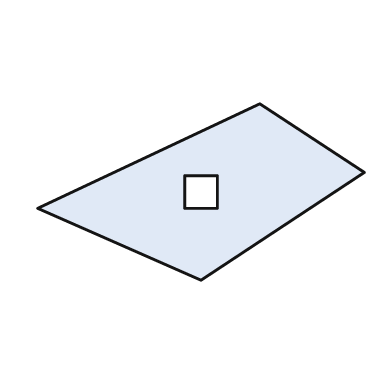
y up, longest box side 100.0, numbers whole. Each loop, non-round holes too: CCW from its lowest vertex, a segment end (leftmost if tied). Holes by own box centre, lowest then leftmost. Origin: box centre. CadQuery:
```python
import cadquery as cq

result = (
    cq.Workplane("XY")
    .moveTo(0.0, -27.0)
    .lineTo(50.0, 6.0)
    .lineTo(18.0, 27.0)
    .lineTo(-50.0, -5.0)
    .close()
    .moveTo(-5.0, -5.0)
    .lineTo(5.0, -5.0)
    .lineTo(5.0, 5.0)
    .lineTo(-5.0, 5.0)
    .close()
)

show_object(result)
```